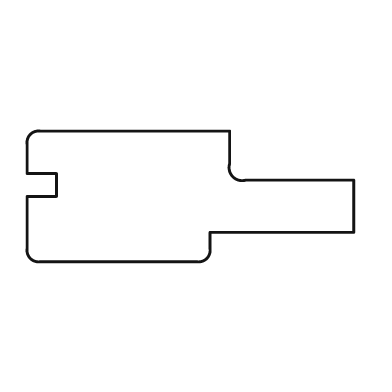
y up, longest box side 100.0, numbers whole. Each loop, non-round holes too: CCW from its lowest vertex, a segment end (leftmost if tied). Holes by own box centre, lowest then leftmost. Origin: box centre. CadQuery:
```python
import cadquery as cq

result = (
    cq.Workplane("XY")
    .moveTo(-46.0, -20.0)
    .lineTo(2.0, -20.0)
    .threePointArc((5.0, -19.0), (6.0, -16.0))
    .lineTo(6.0, -11.0)
    .lineTo(50.0, -11.0)
    .lineTo(50.0, 5.0)
    .lineTo(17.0, 5.0)
    .threePointArc((13.0, 6.0), (12.0, 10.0))
    .lineTo(12.0, 20.0)
    .lineTo(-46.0, 20.0)
    .threePointArc((-49.0, 19.0), (-50.0, 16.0))
    .lineTo(-50.0, 7.0)
    .lineTo(-41.0, 7.0)
    .lineTo(-41.0, 0.0)
    .lineTo(-50.0, 0.0)
    .lineTo(-50.0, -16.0)
    .threePointArc((-49.0, -19.0), (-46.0, -20.0))
    .close()
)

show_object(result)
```